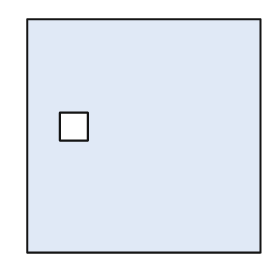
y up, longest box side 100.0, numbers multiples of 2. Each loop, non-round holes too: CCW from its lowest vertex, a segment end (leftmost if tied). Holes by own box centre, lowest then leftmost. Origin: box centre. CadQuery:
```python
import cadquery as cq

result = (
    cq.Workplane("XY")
    .moveTo(-50.0, -50.0)
    .lineTo(50.0, -50.0)
    .lineTo(50.0, 50.0)
    .lineTo(-50.0, 50.0)
    .close()
    .moveTo(-36.0, -2.0)
    .lineTo(-24.0, -2.0)
    .lineTo(-24.0, 10.0)
    .lineTo(-36.0, 10.0)
    .close()
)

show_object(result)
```